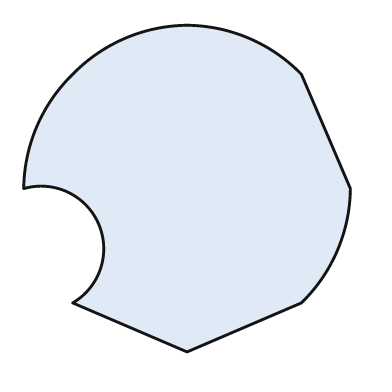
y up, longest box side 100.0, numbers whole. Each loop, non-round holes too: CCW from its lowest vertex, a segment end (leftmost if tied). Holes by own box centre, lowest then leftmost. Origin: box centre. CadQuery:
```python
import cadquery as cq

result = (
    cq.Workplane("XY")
    .moveTo(0.0, -50.0)
    .lineTo(35.0, -35.0)
    .threePointArc((46.0, -19.0), (50.0, 0.0))
    .lineTo(35.0, 35.0)
    .threePointArc((19.0, 46.0), (0.0, 50.0))
    .threePointArc((-19.0, 46.0), (-35.0, 35.0))
    .threePointArc((-46.0, 19.0), (-50.0, 0.0))
    .threePointArc((-27.0, -11.0), (-35.0, -35.0))
    .close()
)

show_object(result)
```